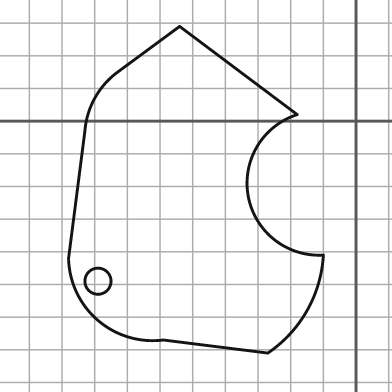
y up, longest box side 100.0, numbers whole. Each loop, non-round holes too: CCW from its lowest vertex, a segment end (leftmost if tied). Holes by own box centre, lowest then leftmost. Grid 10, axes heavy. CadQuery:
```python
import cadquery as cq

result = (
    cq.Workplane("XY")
    .moveTo(-27.0, -71.0)
    .threePointArc((-15.0, -58.0), (-10.0, -41.0))
    .threePointArc((-33.0, -23.0), (-18.0, 2.0))
    .lineTo(-54.0, 29.0)
    .lineTo(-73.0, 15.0)
    .threePointArc((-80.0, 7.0), (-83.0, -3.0))
    .lineTo(-88.0, -42.0)
    .threePointArc((-79.0, -61.0), (-59.0, -67.0))
    .close()
    .moveTo(-79.0, -49.0)
    .circle(4.0)
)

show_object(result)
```